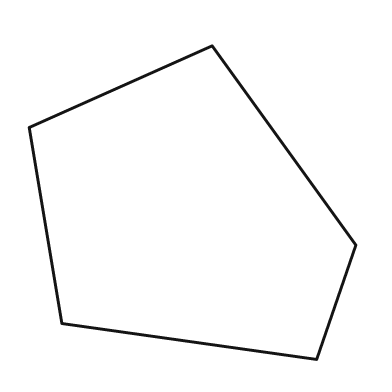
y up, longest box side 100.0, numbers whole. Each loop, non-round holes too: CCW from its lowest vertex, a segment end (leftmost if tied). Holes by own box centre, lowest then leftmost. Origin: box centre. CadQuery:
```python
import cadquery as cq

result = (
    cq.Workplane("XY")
    .moveTo(38.0, -48.0)
    .lineTo(50.0, -13.0)
    .lineTo(6.0, 48.0)
    .lineTo(-50.0, 23.0)
    .lineTo(-40.0, -37.0)
    .close()
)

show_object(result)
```